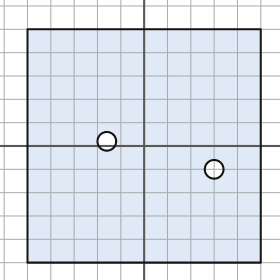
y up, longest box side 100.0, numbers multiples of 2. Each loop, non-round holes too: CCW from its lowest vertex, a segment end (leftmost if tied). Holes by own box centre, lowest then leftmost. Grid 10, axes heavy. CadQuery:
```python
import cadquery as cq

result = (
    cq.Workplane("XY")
    .moveTo(-50.0, -50.0)
    .lineTo(50.0, -50.0)
    .lineTo(50.0, 50.0)
    .lineTo(-50.0, 50.0)
    .close()
    .moveTo(30.0, -10.0)
    .circle(4.0)
    .moveTo(-16.0, 2.0)
    .circle(4.0)
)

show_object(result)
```